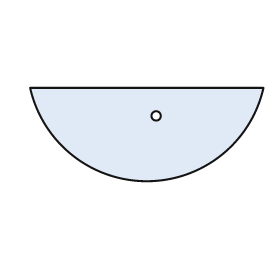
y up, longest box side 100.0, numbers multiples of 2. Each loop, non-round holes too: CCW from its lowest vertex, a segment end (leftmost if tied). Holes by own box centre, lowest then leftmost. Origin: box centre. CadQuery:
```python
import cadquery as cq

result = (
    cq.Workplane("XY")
    .moveTo(-50.0, 20.0)
    .threePointArc((0.0, -20.0), (50.0, 20.0))
    .close()
    .moveTo(4.0, 8.0)
    .circle(2.0)
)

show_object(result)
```